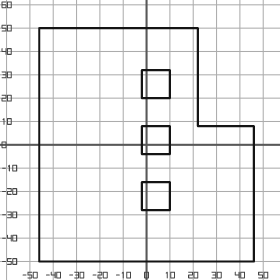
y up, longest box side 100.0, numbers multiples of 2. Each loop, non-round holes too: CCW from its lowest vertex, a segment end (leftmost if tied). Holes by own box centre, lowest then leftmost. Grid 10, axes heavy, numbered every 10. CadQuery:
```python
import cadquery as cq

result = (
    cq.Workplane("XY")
    .moveTo(-46.0, -50.0)
    .lineTo(46.0, -50.0)
    .lineTo(46.0, 8.0)
    .lineTo(22.0, 8.0)
    .lineTo(22.0, 50.0)
    .lineTo(-46.0, 50.0)
    .close()
    .moveTo(-2.0, -28.0)
    .lineTo(10.0, -28.0)
    .lineTo(10.0, -16.0)
    .lineTo(-2.0, -16.0)
    .close()
    .moveTo(-2.0, -4.0)
    .lineTo(10.0, -4.0)
    .lineTo(10.0, 8.0)
    .lineTo(-2.0, 8.0)
    .close()
    .moveTo(-2.0, 20.0)
    .lineTo(10.0, 20.0)
    .lineTo(10.0, 32.0)
    .lineTo(-2.0, 32.0)
    .close()
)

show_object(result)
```